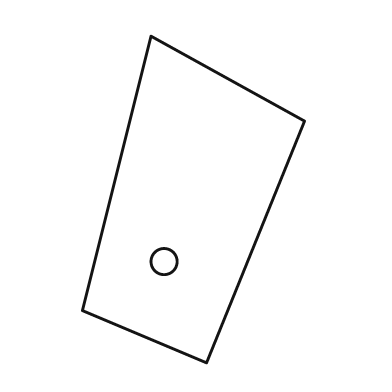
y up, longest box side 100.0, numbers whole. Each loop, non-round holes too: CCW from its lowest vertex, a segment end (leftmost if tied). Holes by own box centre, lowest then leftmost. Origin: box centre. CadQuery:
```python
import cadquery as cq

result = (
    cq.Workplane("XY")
    .moveTo(4.0, -50.0)
    .lineTo(34.0, 24.0)
    .lineTo(-13.0, 50.0)
    .lineTo(-34.0, -34.0)
    .close()
    .moveTo(-9.0, -19.0)
    .circle(4.0)
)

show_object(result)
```